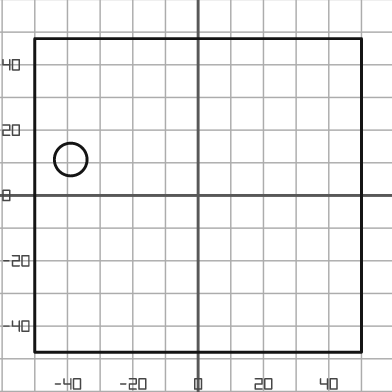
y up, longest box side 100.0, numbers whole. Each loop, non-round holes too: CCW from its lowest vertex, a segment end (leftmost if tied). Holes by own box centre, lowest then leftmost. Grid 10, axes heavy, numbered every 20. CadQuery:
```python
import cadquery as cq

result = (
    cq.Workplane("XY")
    .moveTo(-50.0, -48.0)
    .lineTo(50.0, -48.0)
    .lineTo(50.0, 48.0)
    .lineTo(-50.0, 48.0)
    .close()
    .moveTo(-39.0, 11.0)
    .circle(5.0)
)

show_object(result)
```